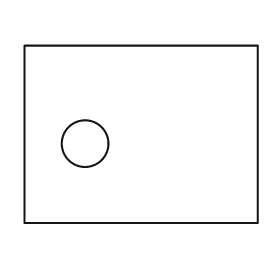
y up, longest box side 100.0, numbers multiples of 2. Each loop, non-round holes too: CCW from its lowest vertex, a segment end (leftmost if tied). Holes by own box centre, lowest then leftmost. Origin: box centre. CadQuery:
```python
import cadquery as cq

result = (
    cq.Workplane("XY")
    .moveTo(-50.0, -38.0)
    .lineTo(50.0, -38.0)
    .lineTo(50.0, 38.0)
    .lineTo(-50.0, 38.0)
    .close()
    .moveTo(-24.0, -4.0)
    .circle(10.0)
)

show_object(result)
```